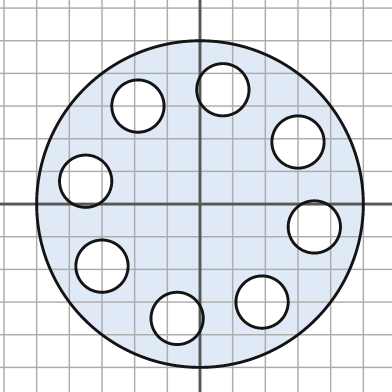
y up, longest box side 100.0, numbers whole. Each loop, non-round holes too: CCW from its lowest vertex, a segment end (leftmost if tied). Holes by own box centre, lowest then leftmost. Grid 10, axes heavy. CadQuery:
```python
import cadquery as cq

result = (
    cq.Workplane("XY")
    .moveTo(0.0, 0.0)
    .circle(50.0)
    .moveTo(-7.0, -35.0)
    .circle(8.0)
    .moveTo(19.0, -30.0)
    .circle(8.0)
    .moveTo(-30.0, -19.0)
    .circle(8.0)
    .moveTo(35.0, -7.0)
    .circle(8.0)
    .moveTo(-35.0, 7.0)
    .circle(8.0)
    .moveTo(30.0, 19.0)
    .circle(8.0)
    .moveTo(-19.0, 30.0)
    .circle(8.0)
    .moveTo(7.0, 35.0)
    .circle(8.0)
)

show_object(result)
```